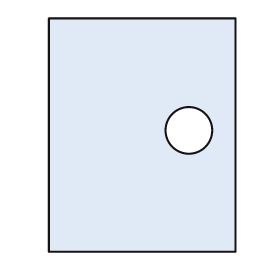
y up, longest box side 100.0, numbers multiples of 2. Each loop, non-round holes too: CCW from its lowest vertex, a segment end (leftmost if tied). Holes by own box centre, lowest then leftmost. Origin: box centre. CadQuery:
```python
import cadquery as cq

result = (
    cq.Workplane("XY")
    .moveTo(-40.0, -50.0)
    .lineTo(40.0, -50.0)
    .lineTo(40.0, 50.0)
    .lineTo(-40.0, 50.0)
    .close()
    .moveTo(20.0, 2.0)
    .circle(10.0)
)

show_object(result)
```